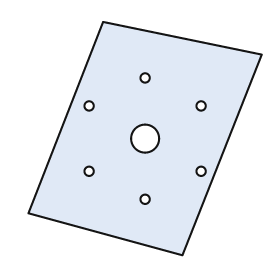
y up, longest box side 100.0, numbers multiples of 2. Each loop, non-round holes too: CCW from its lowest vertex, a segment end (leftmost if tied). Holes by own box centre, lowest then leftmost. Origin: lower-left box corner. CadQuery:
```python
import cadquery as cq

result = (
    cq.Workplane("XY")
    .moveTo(66.0, 0.0)
    .lineTo(100.0, 86.0)
    .lineTo(32.0, 100.0)
    .lineTo(0.0, 18.0)
    .close()
    .moveTo(50.0, 24.0)
    .circle(2.0)
    .moveTo(26.0, 36.0)
    .circle(2.0)
    .moveTo(74.0, 36.0)
    .circle(2.0)
    .moveTo(50.0, 50.0)
    .circle(6.0)
    .moveTo(26.0, 64.0)
    .circle(2.0)
    .moveTo(74.0, 64.0)
    .circle(2.0)
    .moveTo(50.0, 76.0)
    .circle(2.0)
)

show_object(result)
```